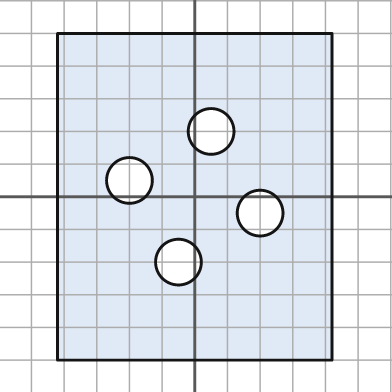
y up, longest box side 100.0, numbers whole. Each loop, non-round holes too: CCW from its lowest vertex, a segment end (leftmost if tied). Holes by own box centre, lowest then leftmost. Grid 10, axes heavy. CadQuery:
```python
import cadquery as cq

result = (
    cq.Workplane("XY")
    .moveTo(-42.0, -50.0)
    .lineTo(42.0, -50.0)
    .lineTo(42.0, 50.0)
    .lineTo(-42.0, 50.0)
    .close()
    .moveTo(-5.0, -20.0)
    .circle(7.0)
    .moveTo(20.0, -5.0)
    .circle(7.0)
    .moveTo(-20.0, 5.0)
    .circle(7.0)
    .moveTo(5.0, 20.0)
    .circle(7.0)
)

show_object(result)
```